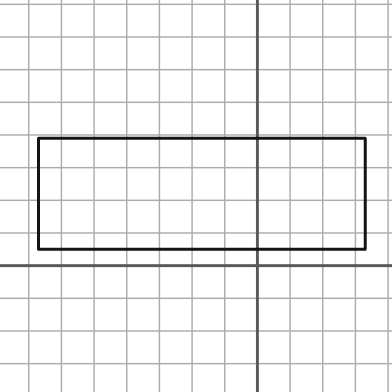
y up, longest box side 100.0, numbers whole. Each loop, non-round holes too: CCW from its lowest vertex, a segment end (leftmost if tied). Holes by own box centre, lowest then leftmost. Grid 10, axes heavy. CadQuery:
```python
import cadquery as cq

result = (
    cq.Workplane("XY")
    .moveTo(-67.0, 5.0)
    .lineTo(33.0, 5.0)
    .lineTo(33.0, 39.0)
    .lineTo(-67.0, 39.0)
    .close()
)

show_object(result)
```